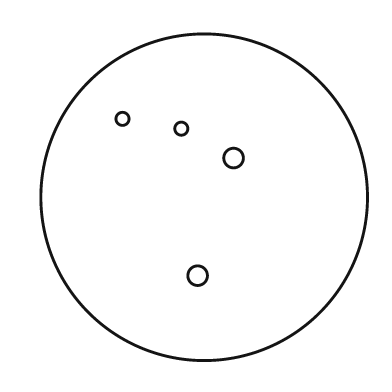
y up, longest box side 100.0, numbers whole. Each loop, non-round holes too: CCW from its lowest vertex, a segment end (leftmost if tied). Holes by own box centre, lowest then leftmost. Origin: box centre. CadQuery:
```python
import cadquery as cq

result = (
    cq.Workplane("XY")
    .moveTo(0.0, 0.0)
    .circle(50.0)
    .moveTo(-2.0, -24.0)
    .circle(3.0)
    .moveTo(9.0, 12.0)
    .circle(3.0)
    .moveTo(-7.0, 21.0)
    .circle(2.0)
    .moveTo(-25.0, 24.0)
    .circle(2.0)
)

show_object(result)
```